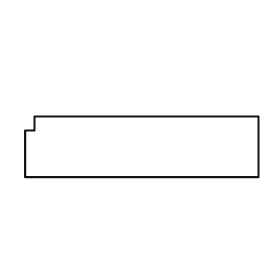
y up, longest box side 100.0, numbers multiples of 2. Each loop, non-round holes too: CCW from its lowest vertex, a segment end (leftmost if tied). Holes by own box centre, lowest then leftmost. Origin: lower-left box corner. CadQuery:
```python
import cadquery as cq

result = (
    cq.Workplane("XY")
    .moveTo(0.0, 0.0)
    .lineTo(100.0, 0.0)
    .lineTo(100.0, 26.0)
    .lineTo(4.0, 26.0)
    .lineTo(4.0, 20.0)
    .lineTo(0.0, 20.0)
    .close()
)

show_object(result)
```